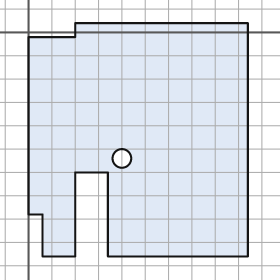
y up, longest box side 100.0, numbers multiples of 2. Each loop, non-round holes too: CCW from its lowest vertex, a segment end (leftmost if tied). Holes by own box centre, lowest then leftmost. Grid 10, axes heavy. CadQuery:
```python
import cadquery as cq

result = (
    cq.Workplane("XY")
    .moveTo(6.0, -96.0)
    .lineTo(20.0, -96.0)
    .lineTo(20.0, -60.0)
    .lineTo(34.0, -60.0)
    .lineTo(34.0, -96.0)
    .lineTo(94.0, -96.0)
    .lineTo(94.0, 4.0)
    .lineTo(20.0, 4.0)
    .lineTo(20.0, -2.0)
    .lineTo(0.0, -2.0)
    .lineTo(0.0, -78.0)
    .lineTo(6.0, -78.0)
    .close()
    .moveTo(40.0, -54.0)
    .circle(4.0)
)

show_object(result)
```